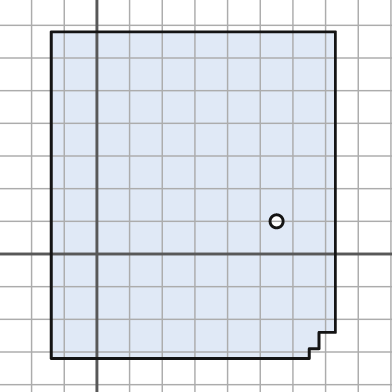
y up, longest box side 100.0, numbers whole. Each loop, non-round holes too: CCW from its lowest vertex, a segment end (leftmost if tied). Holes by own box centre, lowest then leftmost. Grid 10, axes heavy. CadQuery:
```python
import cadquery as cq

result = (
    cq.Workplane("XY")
    .moveTo(-14.0, -32.0)
    .lineTo(65.0, -32.0)
    .lineTo(65.0, -29.0)
    .lineTo(68.0, -29.0)
    .lineTo(68.0, -24.0)
    .lineTo(73.0, -24.0)
    .lineTo(73.0, 68.0)
    .lineTo(-14.0, 68.0)
    .close()
    .moveTo(55.0, 10.0)
    .circle(2.0)
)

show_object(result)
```